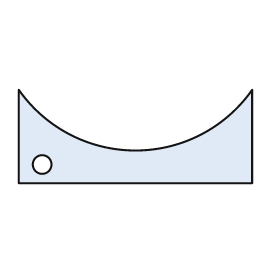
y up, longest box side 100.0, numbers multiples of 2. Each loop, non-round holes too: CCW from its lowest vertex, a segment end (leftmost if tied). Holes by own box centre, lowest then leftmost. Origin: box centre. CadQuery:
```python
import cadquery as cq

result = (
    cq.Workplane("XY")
    .moveTo(-50.0, -20.0)
    .lineTo(50.0, -20.0)
    .lineTo(50.0, 20.0)
    .threePointArc((0.0, -6.0), (-50.0, 20.0))
    .close()
    .moveTo(-40.0, -12.0)
    .circle(4.0)
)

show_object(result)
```